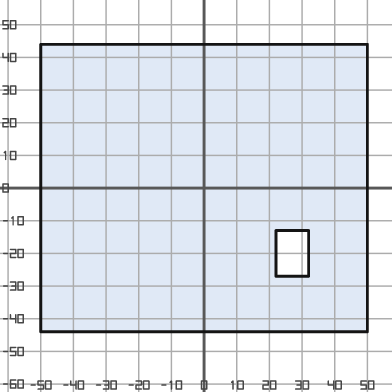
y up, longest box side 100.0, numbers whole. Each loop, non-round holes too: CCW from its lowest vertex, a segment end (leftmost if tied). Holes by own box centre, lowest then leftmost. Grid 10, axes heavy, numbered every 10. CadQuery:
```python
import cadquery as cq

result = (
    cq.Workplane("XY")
    .moveTo(-50.0, -44.0)
    .lineTo(50.0, -44.0)
    .lineTo(50.0, 44.0)
    .lineTo(-50.0, 44.0)
    .close()
    .moveTo(22.0, -27.0)
    .lineTo(32.0, -27.0)
    .lineTo(32.0, -13.0)
    .lineTo(22.0, -13.0)
    .close()
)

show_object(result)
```